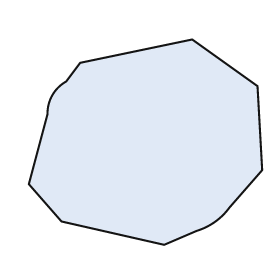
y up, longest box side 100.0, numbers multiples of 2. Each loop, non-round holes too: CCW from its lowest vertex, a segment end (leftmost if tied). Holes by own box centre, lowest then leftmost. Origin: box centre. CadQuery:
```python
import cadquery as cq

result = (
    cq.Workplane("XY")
    .moveTo(8.0, -44.0)
    .lineTo(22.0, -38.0)
    .threePointArc((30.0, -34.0), (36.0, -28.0))
    .lineTo(50.0, -12.0)
    .lineTo(48.0, 24.0)
    .lineTo(20.0, 44.0)
    .lineTo(-28.0, 34.0)
    .lineTo(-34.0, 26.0)
    .threePointArc((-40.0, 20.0), (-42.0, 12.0))
    .lineTo(-50.0, -18.0)
    .lineTo(-36.0, -34.0)
    .close()
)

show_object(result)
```